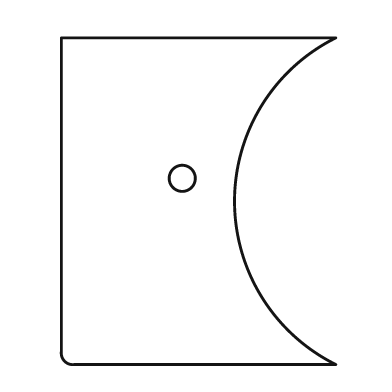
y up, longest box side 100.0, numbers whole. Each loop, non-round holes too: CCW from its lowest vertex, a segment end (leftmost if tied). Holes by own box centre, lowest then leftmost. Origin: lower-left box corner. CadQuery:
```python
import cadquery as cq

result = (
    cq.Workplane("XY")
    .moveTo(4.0, 0.0)
    .lineTo(84.0, 0.0)
    .threePointArc((53.0, 50.0), (84.0, 100.0))
    .lineTo(0.0, 100.0)
    .lineTo(0.0, 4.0)
    .threePointArc((1.0, 1.0), (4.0, 0.0))
    .close()
    .moveTo(37.0, 57.0)
    .circle(4.0)
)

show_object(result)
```